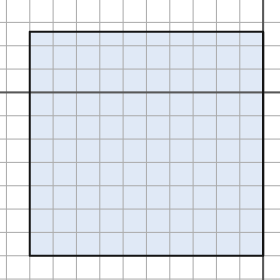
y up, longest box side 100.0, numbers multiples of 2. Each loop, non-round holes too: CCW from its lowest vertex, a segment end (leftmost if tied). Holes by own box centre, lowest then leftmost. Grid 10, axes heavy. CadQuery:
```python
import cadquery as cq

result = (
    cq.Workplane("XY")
    .moveTo(-100.0, -70.0)
    .lineTo(0.0, -70.0)
    .lineTo(0.0, 26.0)
    .lineTo(-100.0, 26.0)
    .close()
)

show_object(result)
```